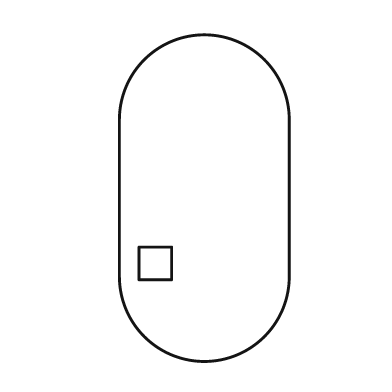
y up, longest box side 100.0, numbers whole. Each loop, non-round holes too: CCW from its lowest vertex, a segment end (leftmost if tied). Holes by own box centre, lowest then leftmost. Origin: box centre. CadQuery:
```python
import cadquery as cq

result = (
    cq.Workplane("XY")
    .moveTo(-26.0, -24.0)
    .threePointArc((0.0, -50.0), (26.0, -24.0))
    .lineTo(26.0, 24.0)
    .threePointArc((0.0, 50.0), (-26.0, 24.0))
    .close()
    .moveTo(-20.0, -25.0)
    .lineTo(-10.0, -25.0)
    .lineTo(-10.0, -15.0)
    .lineTo(-20.0, -15.0)
    .close()
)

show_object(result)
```